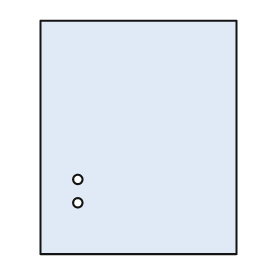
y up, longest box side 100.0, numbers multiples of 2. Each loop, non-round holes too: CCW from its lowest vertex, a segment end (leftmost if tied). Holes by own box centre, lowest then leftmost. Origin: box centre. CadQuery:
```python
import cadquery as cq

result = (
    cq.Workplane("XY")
    .moveTo(-42.0, -50.0)
    .lineTo(42.0, -50.0)
    .lineTo(42.0, 50.0)
    .lineTo(-42.0, 50.0)
    .close()
    .moveTo(-26.0, -28.0)
    .circle(2.0)
    .moveTo(-26.0, -18.0)
    .circle(2.0)
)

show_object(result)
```